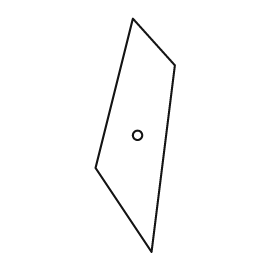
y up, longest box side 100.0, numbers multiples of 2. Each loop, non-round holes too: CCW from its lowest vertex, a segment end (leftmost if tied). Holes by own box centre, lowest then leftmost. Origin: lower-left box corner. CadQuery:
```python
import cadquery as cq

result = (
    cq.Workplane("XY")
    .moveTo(24.0, 0.0)
    .lineTo(34.0, 80.0)
    .lineTo(16.0, 100.0)
    .lineTo(0.0, 36.0)
    .close()
    .moveTo(18.0, 50.0)
    .circle(2.0)
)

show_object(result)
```